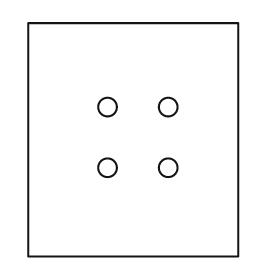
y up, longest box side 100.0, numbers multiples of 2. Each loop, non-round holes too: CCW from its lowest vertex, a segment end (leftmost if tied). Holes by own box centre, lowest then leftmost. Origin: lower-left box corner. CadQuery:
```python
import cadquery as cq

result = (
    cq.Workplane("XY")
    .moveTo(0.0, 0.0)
    .lineTo(90.0, 0.0)
    .lineTo(90.0, 100.0)
    .lineTo(0.0, 100.0)
    .close()
    .moveTo(34.0, 38.0)
    .circle(4.0)
    .moveTo(60.0, 38.0)
    .circle(4.0)
    .moveTo(34.0, 64.0)
    .circle(4.0)
    .moveTo(60.0, 64.0)
    .circle(4.0)
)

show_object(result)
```